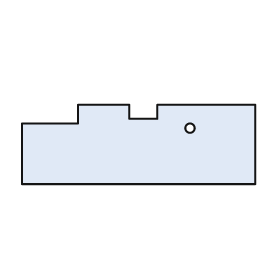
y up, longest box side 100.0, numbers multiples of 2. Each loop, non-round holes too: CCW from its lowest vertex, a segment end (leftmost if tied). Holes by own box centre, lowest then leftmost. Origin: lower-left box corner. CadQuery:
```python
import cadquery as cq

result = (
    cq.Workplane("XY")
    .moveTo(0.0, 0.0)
    .lineTo(100.0, 0.0)
    .lineTo(100.0, 34.0)
    .lineTo(58.0, 34.0)
    .lineTo(58.0, 28.0)
    .lineTo(46.0, 28.0)
    .lineTo(46.0, 34.0)
    .lineTo(24.0, 34.0)
    .lineTo(24.0, 26.0)
    .lineTo(0.0, 26.0)
    .close()
    .moveTo(72.0, 24.0)
    .circle(2.0)
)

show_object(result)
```